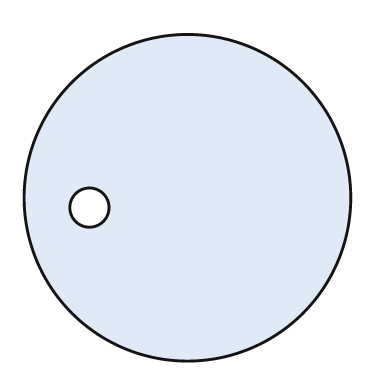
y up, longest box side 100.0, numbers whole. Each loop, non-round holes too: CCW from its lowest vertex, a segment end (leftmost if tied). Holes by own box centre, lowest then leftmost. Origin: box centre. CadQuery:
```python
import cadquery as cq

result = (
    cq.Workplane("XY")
    .moveTo(0.0, 0.0)
    .circle(50.0)
    .moveTo(-30.0, -3.0)
    .circle(6.0)
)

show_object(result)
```